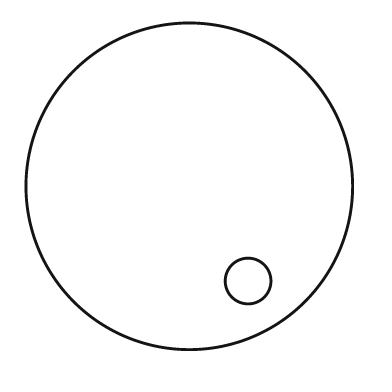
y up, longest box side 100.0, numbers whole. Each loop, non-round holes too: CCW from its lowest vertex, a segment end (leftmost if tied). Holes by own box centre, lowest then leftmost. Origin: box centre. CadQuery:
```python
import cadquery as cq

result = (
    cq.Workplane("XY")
    .moveTo(0.0, 0.0)
    .circle(50.0)
    .moveTo(18.0, -29.0)
    .circle(7.0)
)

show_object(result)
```